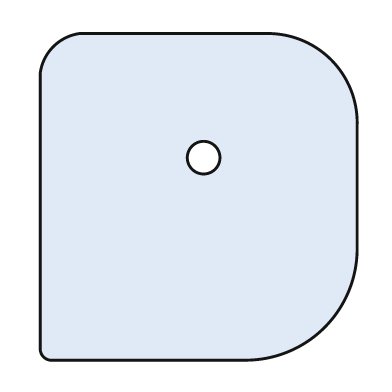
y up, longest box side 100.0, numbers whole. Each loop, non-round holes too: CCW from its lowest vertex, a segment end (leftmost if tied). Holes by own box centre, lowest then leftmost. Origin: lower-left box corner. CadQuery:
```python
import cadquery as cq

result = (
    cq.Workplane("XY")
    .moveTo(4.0, 0.0)
    .lineTo(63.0, 0.0)
    .threePointArc((87.0, 10.0), (97.0, 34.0))
    .lineTo(97.0, 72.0)
    .threePointArc((89.0, 92.0), (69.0, 100.0))
    .lineTo(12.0, 100.0)
    .threePointArc((4.0, 96.0), (0.0, 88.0))
    .lineTo(0.0, 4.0)
    .threePointArc((1.0, 1.0), (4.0, 0.0))
    .close()
    .moveTo(50.0, 62.0)
    .circle(5.0)
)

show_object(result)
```